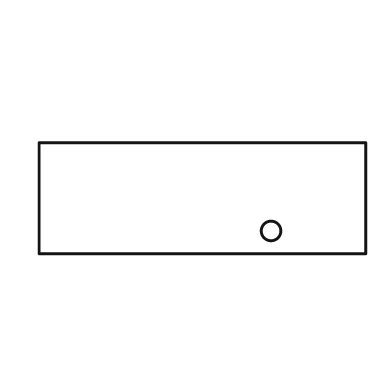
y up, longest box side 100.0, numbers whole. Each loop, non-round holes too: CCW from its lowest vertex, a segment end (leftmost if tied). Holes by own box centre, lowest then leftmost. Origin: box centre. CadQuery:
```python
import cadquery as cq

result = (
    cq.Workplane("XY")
    .moveTo(-50.0, -17.0)
    .lineTo(50.0, -17.0)
    .lineTo(50.0, 17.0)
    .lineTo(-50.0, 17.0)
    .close()
    .moveTo(21.0, -10.0)
    .circle(3.0)
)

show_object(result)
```